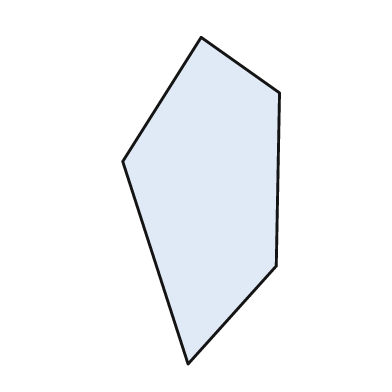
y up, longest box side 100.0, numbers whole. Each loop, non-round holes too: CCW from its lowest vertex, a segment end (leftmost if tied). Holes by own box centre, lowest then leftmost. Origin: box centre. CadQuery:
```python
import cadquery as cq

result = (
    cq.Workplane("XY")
    .moveTo(-4.0, -50.0)
    .lineTo(23.0, -20.0)
    .lineTo(24.0, 33.0)
    .lineTo(0.0, 50.0)
    .lineTo(-24.0, 12.0)
    .close()
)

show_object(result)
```